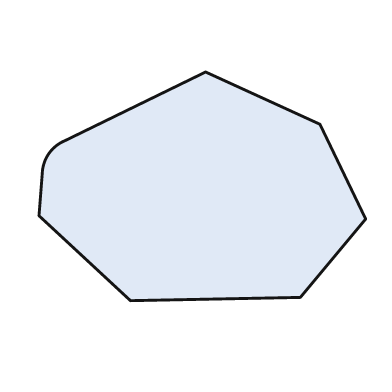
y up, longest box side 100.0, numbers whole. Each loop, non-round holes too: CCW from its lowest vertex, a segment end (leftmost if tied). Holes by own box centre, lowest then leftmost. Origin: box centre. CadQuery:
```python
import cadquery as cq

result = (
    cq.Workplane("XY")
    .moveTo(-22.0, -35.0)
    .lineTo(30.0, -34.0)
    .lineTo(50.0, -10.0)
    .lineTo(36.0, 19.0)
    .lineTo(1.0, 35.0)
    .lineTo(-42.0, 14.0)
    .threePointArc((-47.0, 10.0), (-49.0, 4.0))
    .lineTo(-50.0, -9.0)
    .close()
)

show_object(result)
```